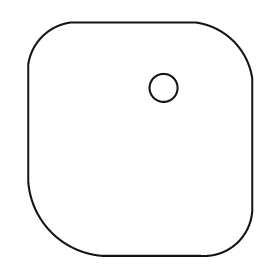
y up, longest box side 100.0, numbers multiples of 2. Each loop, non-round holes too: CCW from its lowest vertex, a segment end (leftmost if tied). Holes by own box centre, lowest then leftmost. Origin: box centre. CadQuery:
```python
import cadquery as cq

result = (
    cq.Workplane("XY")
    .moveTo(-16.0, -50.0)
    .lineTo(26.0, -50.0)
    .threePointArc((42.0, -44.0), (48.0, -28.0))
    .lineTo(48.0, 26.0)
    .threePointArc((40.0, 42.0), (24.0, 50.0))
    .lineTo(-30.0, 50.0)
    .threePointArc((-42.0, 44.0), (-48.0, 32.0))
    .lineTo(-48.0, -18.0)
    .threePointArc((-38.0, -40.0), (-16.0, -50.0))
    .close()
    .moveTo(10.0, 22.0)
    .circle(6.0)
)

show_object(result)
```